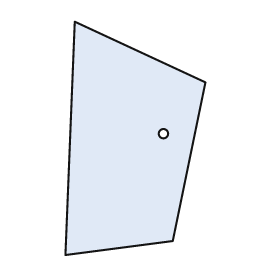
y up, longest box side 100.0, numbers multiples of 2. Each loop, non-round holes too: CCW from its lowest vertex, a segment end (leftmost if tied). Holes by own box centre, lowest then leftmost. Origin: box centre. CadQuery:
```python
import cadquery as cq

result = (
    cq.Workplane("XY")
    .moveTo(-30.0, -50.0)
    .lineTo(16.0, -44.0)
    .lineTo(30.0, 24.0)
    .lineTo(-26.0, 50.0)
    .close()
    .moveTo(12.0, 2.0)
    .circle(2.0)
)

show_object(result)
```